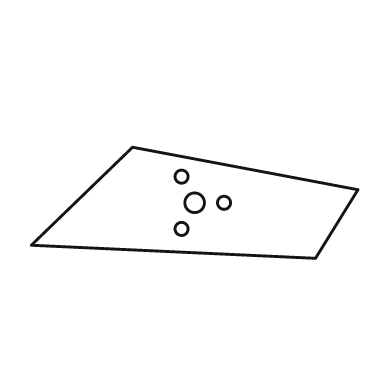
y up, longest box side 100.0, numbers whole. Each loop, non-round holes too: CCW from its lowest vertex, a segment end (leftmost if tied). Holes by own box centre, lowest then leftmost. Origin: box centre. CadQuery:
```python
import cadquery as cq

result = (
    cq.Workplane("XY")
    .moveTo(37.0, -17.0)
    .lineTo(50.0, 4.0)
    .lineTo(-19.0, 17.0)
    .lineTo(-50.0, -13.0)
    .close()
    .moveTo(-4.0, -8.0)
    .circle(2.0)
    .moveTo(0.0, 0.0)
    .circle(3.0)
    .moveTo(9.0, 0.0)
    .circle(2.0)
    .moveTo(-4.0, 8.0)
    .circle(2.0)
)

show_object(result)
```